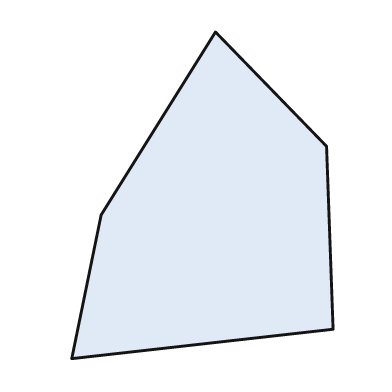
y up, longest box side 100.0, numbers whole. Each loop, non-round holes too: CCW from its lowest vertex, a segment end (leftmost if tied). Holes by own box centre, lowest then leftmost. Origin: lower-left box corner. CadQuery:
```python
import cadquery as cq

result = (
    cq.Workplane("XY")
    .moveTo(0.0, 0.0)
    .lineTo(80.0, 9.0)
    .lineTo(78.0, 65.0)
    .lineTo(44.0, 100.0)
    .lineTo(9.0, 44.0)
    .close()
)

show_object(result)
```